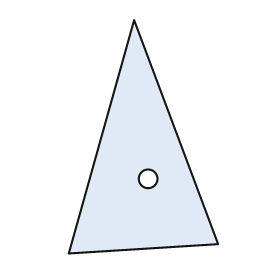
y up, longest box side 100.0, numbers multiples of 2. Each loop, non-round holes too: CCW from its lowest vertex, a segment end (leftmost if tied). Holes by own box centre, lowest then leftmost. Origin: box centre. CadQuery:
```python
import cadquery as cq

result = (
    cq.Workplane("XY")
    .moveTo(-32.0, -50.0)
    .lineTo(32.0, -46.0)
    .lineTo(-4.0, 50.0)
    .close()
    .moveTo(2.0, -18.0)
    .circle(4.0)
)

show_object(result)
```